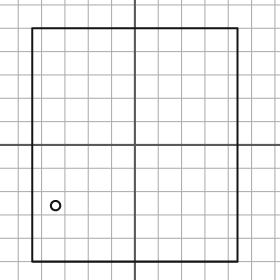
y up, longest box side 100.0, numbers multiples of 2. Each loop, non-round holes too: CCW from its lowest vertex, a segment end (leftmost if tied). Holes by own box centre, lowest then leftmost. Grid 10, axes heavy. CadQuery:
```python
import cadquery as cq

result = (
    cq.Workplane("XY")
    .moveTo(-44.0, -50.0)
    .lineTo(44.0, -50.0)
    .lineTo(44.0, 50.0)
    .lineTo(-44.0, 50.0)
    .close()
    .moveTo(-34.0, -26.0)
    .circle(2.0)
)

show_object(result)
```